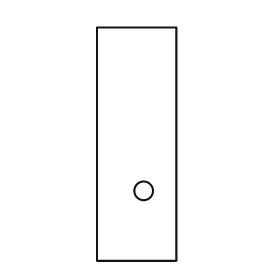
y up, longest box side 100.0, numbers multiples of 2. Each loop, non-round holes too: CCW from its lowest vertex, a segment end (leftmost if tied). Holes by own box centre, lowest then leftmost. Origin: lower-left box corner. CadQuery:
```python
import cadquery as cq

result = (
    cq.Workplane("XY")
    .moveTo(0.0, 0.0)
    .lineTo(34.0, 0.0)
    .lineTo(34.0, 100.0)
    .lineTo(0.0, 100.0)
    .close()
    .moveTo(20.0, 30.0)
    .circle(4.0)
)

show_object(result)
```